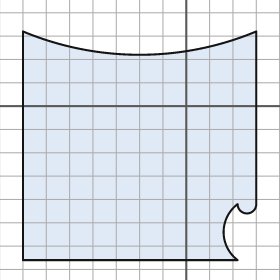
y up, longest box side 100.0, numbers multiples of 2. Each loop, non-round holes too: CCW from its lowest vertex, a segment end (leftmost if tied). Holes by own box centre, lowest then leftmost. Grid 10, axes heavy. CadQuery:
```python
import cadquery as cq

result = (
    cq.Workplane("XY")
    .moveTo(-70.0, -66.0)
    .lineTo(22.0, -66.0)
    .threePointArc((16.0, -54.0), (22.0, -42.0))
    .threePointArc((26.0, -46.0), (30.0, -42.0))
    .lineTo(30.0, 32.0)
    .threePointArc((-20.0, 22.0), (-70.0, 32.0))
    .close()
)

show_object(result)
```